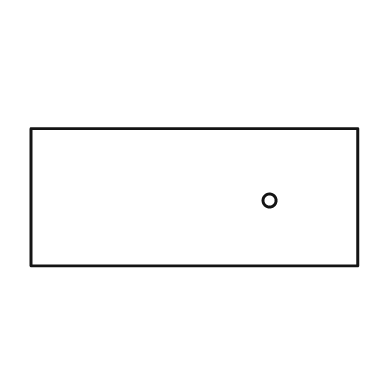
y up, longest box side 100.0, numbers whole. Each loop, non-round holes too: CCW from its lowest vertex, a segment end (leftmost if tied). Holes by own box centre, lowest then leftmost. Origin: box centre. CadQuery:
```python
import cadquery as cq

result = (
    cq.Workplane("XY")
    .moveTo(-50.0, -21.0)
    .lineTo(50.0, -21.0)
    .lineTo(50.0, 21.0)
    .lineTo(-50.0, 21.0)
    .close()
    .moveTo(23.0, -1.0)
    .circle(2.0)
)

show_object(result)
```